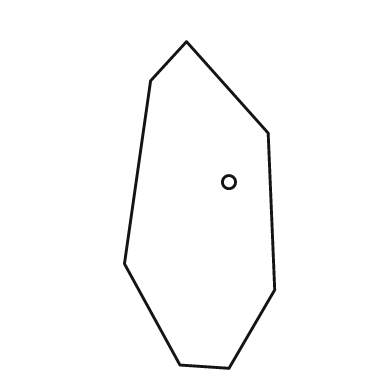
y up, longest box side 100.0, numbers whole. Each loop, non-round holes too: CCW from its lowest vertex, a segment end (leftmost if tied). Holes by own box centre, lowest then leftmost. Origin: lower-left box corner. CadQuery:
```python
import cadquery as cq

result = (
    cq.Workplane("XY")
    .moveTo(32.0, 0.0)
    .lineTo(46.0, 24.0)
    .lineTo(44.0, 72.0)
    .lineTo(19.0, 100.0)
    .lineTo(8.0, 88.0)
    .lineTo(0.0, 32.0)
    .lineTo(17.0, 1.0)
    .close()
    .moveTo(32.0, 57.0)
    .circle(2.0)
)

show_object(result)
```